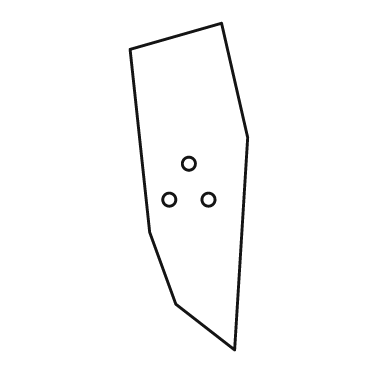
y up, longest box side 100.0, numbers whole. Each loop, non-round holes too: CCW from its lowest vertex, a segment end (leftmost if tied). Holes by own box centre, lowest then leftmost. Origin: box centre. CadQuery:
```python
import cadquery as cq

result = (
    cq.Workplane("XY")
    .moveTo(14.0, -50.0)
    .lineTo(18.0, 15.0)
    .lineTo(10.0, 50.0)
    .lineTo(-18.0, 42.0)
    .lineTo(-12.0, -14.0)
    .lineTo(-4.0, -36.0)
    .close()
    .moveTo(-6.0, -4.0)
    .circle(2.0)
    .moveTo(6.0, -4.0)
    .circle(2.0)
    .moveTo(0.0, 7.0)
    .circle(2.0)
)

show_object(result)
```